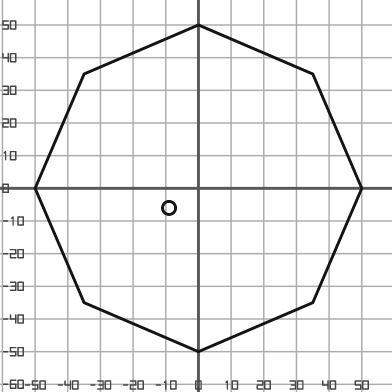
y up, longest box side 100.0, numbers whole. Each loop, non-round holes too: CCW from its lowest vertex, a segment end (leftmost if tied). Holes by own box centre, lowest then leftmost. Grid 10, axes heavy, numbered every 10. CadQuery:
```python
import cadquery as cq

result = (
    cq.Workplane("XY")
    .moveTo(0.0, -50.0)
    .lineTo(35.0, -35.0)
    .lineTo(50.0, 0.0)
    .lineTo(35.0, 35.0)
    .lineTo(0.0, 50.0)
    .lineTo(-35.0, 35.0)
    .lineTo(-50.0, 0.0)
    .lineTo(-35.0, -35.0)
    .close()
    .moveTo(-9.0, -6.0)
    .circle(2.0)
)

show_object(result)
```